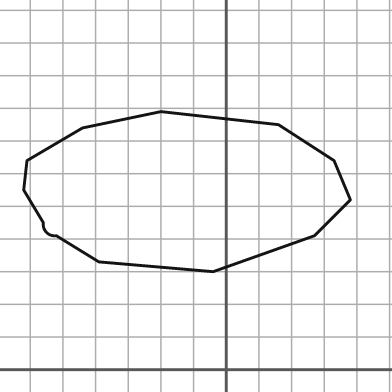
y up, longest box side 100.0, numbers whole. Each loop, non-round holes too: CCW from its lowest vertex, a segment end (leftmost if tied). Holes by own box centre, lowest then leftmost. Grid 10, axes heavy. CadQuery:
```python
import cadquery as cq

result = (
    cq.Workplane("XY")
    .moveTo(-4.0, 30.0)
    .lineTo(27.0, 41.0)
    .lineTo(38.0, 52.0)
    .lineTo(33.0, 64.0)
    .lineTo(16.0, 75.0)
    .lineTo(-20.0, 79.0)
    .lineTo(-44.0, 74.0)
    .lineTo(-61.0, 64.0)
    .lineTo(-62.0, 55.0)
    .lineTo(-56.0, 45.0)
    .threePointArc((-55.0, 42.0), (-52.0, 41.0))
    .lineTo(-39.0, 33.0)
    .close()
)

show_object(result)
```